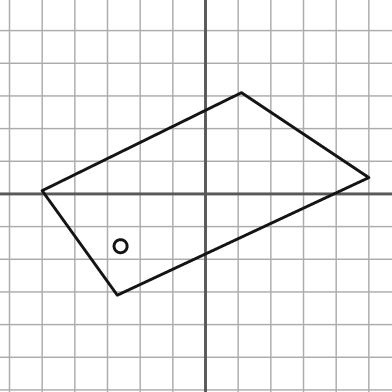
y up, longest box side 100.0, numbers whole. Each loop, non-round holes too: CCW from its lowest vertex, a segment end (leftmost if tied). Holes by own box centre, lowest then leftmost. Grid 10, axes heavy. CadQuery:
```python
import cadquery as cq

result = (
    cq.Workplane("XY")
    .moveTo(-27.0, -31.0)
    .lineTo(50.0, 5.0)
    .lineTo(11.0, 31.0)
    .lineTo(-50.0, 1.0)
    .close()
    .moveTo(-26.0, -16.0)
    .circle(2.0)
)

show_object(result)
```